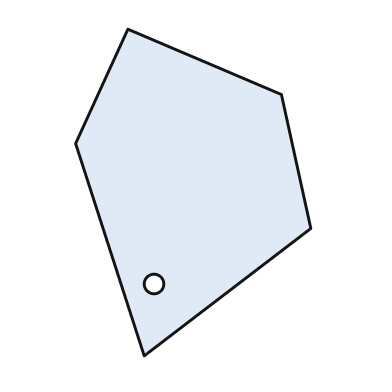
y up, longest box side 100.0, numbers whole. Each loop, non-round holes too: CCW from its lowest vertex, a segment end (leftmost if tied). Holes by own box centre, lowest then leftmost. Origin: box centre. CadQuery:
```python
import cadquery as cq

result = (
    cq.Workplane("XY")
    .moveTo(-15.0, -50.0)
    .lineTo(36.0, -11.0)
    .lineTo(27.0, 30.0)
    .lineTo(-20.0, 50.0)
    .lineTo(-36.0, 15.0)
    .close()
    .moveTo(-12.0, -28.0)
    .circle(3.0)
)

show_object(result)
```